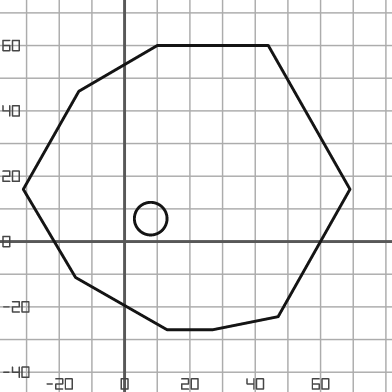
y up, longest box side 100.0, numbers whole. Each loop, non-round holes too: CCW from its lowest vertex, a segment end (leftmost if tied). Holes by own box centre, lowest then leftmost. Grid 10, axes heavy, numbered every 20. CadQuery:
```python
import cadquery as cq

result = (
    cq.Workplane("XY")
    .moveTo(13.0, -27.0)
    .lineTo(27.0, -27.0)
    .lineTo(47.0, -23.0)
    .lineTo(69.0, 16.0)
    .lineTo(44.0, 60.0)
    .lineTo(10.0, 60.0)
    .lineTo(-14.0, 46.0)
    .lineTo(-31.0, 16.0)
    .lineTo(-15.0, -11.0)
    .close()
    .moveTo(8.0, 7.0)
    .circle(5.0)
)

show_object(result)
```